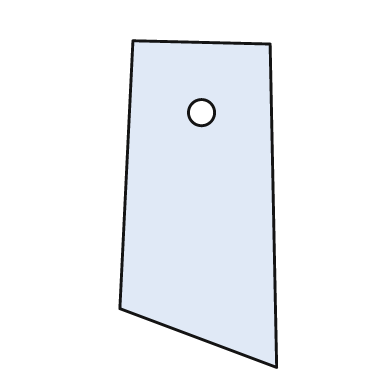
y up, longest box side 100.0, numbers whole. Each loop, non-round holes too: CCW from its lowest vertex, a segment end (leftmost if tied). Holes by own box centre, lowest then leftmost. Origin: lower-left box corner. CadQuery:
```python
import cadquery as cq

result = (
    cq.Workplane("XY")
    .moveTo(48.0, 0.0)
    .lineTo(46.0, 99.0)
    .lineTo(4.0, 100.0)
    .lineTo(0.0, 18.0)
    .close()
    .moveTo(25.0, 78.0)
    .circle(4.0)
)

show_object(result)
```